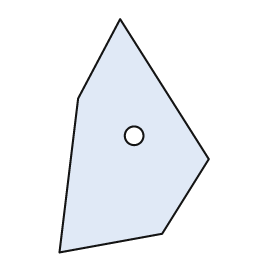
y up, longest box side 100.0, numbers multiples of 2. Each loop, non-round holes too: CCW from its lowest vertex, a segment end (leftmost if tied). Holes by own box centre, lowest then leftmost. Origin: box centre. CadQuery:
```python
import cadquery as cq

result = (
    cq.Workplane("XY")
    .moveTo(-32.0, -50.0)
    .lineTo(12.0, -42.0)
    .lineTo(32.0, -10.0)
    .lineTo(-6.0, 50.0)
    .lineTo(-24.0, 16.0)
    .close()
    .moveTo(0.0, 0.0)
    .circle(4.0)
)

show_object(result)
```